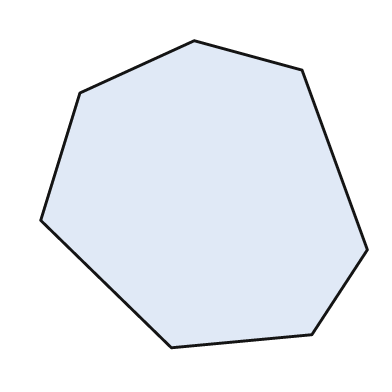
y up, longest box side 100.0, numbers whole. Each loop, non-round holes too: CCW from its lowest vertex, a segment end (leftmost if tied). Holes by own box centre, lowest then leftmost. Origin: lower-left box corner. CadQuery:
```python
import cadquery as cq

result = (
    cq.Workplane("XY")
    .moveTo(40.0, 0.0)
    .lineTo(83.0, 4.0)
    .lineTo(100.0, 30.0)
    .lineTo(80.0, 85.0)
    .lineTo(47.0, 94.0)
    .lineTo(12.0, 78.0)
    .lineTo(0.0, 39.0)
    .close()
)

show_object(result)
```